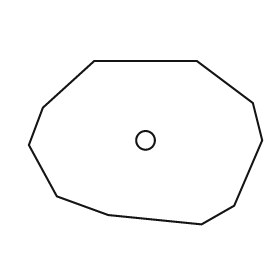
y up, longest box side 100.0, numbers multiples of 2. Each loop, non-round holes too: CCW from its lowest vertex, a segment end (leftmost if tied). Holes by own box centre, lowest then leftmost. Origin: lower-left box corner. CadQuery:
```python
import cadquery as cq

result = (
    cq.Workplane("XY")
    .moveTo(74.0, 0.0)
    .lineTo(88.0, 8.0)
    .lineTo(100.0, 36.0)
    .lineTo(96.0, 52.0)
    .lineTo(72.0, 70.0)
    .lineTo(28.0, 70.0)
    .lineTo(6.0, 50.0)
    .lineTo(0.0, 34.0)
    .lineTo(12.0, 12.0)
    .lineTo(34.0, 4.0)
    .close()
    .moveTo(50.0, 36.0)
    .circle(4.0)
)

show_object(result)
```